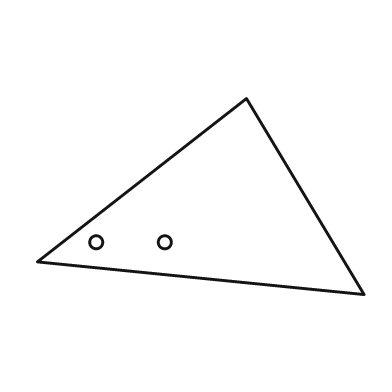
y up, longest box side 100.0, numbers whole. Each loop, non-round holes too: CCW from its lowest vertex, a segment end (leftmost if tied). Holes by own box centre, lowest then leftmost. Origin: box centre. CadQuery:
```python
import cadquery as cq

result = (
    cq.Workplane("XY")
    .moveTo(50.0, -30.0)
    .lineTo(14.0, 30.0)
    .lineTo(-50.0, -20.0)
    .close()
    .moveTo(-32.0, -14.0)
    .circle(2.0)
    .moveTo(-11.0, -14.0)
    .circle(2.0)
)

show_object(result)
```